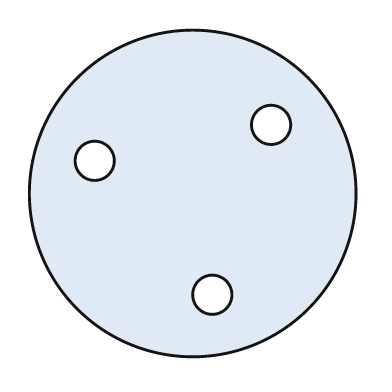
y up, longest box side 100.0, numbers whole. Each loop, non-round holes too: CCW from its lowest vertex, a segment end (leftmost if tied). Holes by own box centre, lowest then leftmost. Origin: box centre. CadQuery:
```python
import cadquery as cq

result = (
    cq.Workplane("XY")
    .moveTo(0.0, 0.0)
    .circle(50.0)
    .moveTo(6.0, -31.0)
    .circle(6.0)
    .moveTo(-30.0, 10.0)
    .circle(6.0)
    .moveTo(24.0, 21.0)
    .circle(6.0)
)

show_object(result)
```